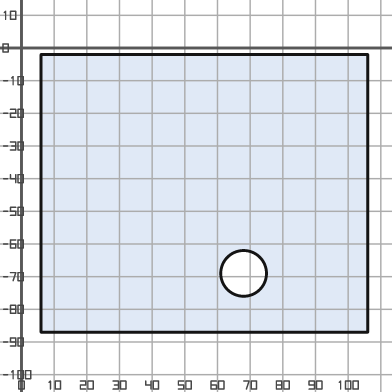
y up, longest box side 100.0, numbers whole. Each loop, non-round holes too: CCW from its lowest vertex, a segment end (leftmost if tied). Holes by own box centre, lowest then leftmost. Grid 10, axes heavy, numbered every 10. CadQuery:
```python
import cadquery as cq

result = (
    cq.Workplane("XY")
    .moveTo(6.0, -87.0)
    .lineTo(106.0, -87.0)
    .lineTo(106.0, -2.0)
    .lineTo(6.0, -2.0)
    .close()
    .moveTo(68.0, -69.0)
    .circle(7.0)
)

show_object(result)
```